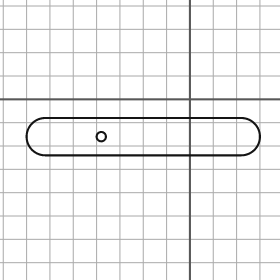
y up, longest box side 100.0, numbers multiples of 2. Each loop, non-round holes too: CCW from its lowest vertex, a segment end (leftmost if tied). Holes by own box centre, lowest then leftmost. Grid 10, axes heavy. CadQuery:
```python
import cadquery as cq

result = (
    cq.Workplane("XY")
    .moveTo(-62.0, -24.0)
    .lineTo(22.0, -24.0)
    .threePointArc((30.0, -16.0), (22.0, -8.0))
    .lineTo(-62.0, -8.0)
    .threePointArc((-70.0, -16.0), (-62.0, -24.0))
    .close()
    .moveTo(-38.0, -16.0)
    .circle(2.0)
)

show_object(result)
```